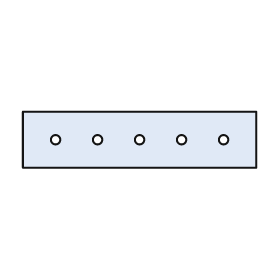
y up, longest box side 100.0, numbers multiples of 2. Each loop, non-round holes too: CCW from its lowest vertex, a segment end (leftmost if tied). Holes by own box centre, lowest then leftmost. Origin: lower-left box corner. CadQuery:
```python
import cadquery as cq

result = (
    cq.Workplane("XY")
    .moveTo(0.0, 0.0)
    .lineTo(100.0, 0.0)
    .lineTo(100.0, 24.0)
    .lineTo(0.0, 24.0)
    .close()
    .moveTo(14.0, 12.0)
    .circle(2.0)
    .moveTo(32.0, 12.0)
    .circle(2.0)
    .moveTo(50.0, 12.0)
    .circle(2.0)
    .moveTo(68.0, 12.0)
    .circle(2.0)
    .moveTo(86.0, 12.0)
    .circle(2.0)
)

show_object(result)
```